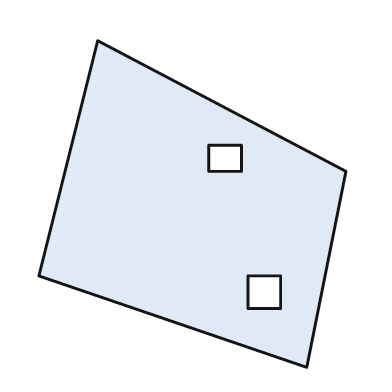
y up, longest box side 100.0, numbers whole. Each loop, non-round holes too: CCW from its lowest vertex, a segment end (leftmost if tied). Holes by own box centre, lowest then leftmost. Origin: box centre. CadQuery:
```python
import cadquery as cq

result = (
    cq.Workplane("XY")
    .moveTo(35.0, -50.0)
    .lineTo(47.0, 10.0)
    .lineTo(-29.0, 50.0)
    .lineTo(-47.0, -22.0)
    .close()
    .moveTo(17.0, -32.0)
    .lineTo(27.0, -32.0)
    .lineTo(27.0, -22.0)
    .lineTo(17.0, -22.0)
    .close()
    .moveTo(5.0, 10.0)
    .lineTo(15.0, 10.0)
    .lineTo(15.0, 18.0)
    .lineTo(5.0, 18.0)
    .close()
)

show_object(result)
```